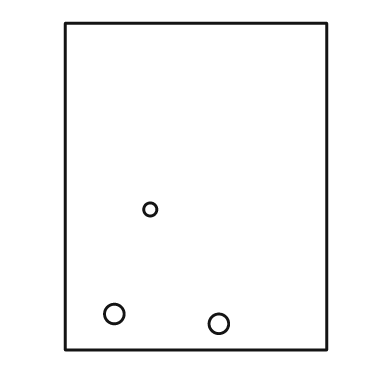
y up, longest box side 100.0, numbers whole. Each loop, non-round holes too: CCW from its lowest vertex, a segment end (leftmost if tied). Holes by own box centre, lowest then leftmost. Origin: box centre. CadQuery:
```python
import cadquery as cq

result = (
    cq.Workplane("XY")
    .moveTo(-40.0, -50.0)
    .lineTo(40.0, -50.0)
    .lineTo(40.0, 50.0)
    .lineTo(-40.0, 50.0)
    .close()
    .moveTo(7.0, -42.0)
    .circle(3.0)
    .moveTo(-25.0, -39.0)
    .circle(3.0)
    .moveTo(-14.0, -7.0)
    .circle(2.0)
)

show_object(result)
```